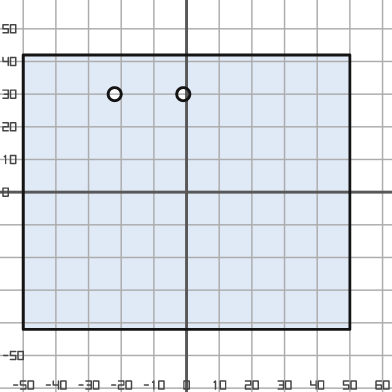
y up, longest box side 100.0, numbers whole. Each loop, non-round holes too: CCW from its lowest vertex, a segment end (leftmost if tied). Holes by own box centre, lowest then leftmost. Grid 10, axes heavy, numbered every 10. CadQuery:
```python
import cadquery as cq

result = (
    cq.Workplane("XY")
    .moveTo(-50.0, -42.0)
    .lineTo(50.0, -42.0)
    .lineTo(50.0, 42.0)
    .lineTo(-50.0, 42.0)
    .close()
    .moveTo(-22.0, 30.0)
    .circle(2.0)
    .moveTo(-1.0, 30.0)
    .circle(2.0)
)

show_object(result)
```